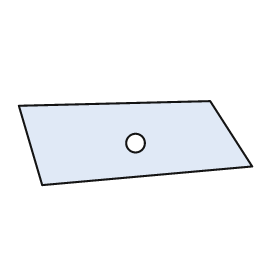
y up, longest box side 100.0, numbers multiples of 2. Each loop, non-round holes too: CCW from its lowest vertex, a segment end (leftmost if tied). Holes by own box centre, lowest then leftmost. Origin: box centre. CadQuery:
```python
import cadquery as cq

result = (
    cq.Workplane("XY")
    .moveTo(-40.0, -18.0)
    .lineTo(50.0, -10.0)
    .lineTo(32.0, 18.0)
    .lineTo(-50.0, 16.0)
    .close()
    .moveTo(0.0, 0.0)
    .circle(4.0)
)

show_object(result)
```